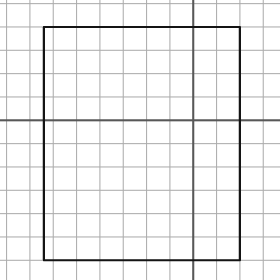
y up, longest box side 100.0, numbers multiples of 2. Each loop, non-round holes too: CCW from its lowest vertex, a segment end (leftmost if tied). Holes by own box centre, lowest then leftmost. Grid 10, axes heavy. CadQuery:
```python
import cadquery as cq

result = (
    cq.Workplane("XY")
    .moveTo(-64.0, -60.0)
    .lineTo(20.0, -60.0)
    .lineTo(20.0, 40.0)
    .lineTo(-64.0, 40.0)
    .close()
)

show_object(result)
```